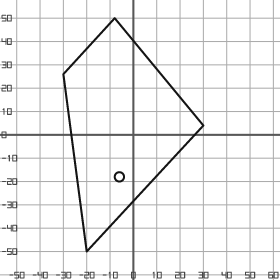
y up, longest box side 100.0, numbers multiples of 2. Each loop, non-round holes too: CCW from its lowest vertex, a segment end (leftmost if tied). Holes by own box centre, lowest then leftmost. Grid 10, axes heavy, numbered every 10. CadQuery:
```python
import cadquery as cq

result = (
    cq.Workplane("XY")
    .moveTo(-20.0, -50.0)
    .lineTo(30.0, 4.0)
    .lineTo(-8.0, 50.0)
    .lineTo(-30.0, 26.0)
    .close()
    .moveTo(-6.0, -18.0)
    .circle(2.0)
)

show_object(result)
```